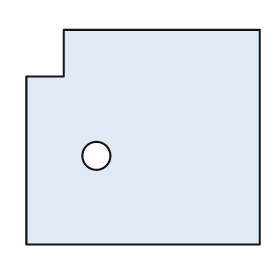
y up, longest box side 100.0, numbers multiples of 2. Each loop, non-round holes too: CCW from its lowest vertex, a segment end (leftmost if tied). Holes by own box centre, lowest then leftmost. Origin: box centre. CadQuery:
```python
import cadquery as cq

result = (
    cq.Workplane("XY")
    .moveTo(-50.0, -46.0)
    .lineTo(50.0, -46.0)
    .lineTo(50.0, 46.0)
    .lineTo(-34.0, 46.0)
    .lineTo(-34.0, 26.0)
    .lineTo(-50.0, 26.0)
    .close()
    .moveTo(-20.0, -8.0)
    .circle(6.0)
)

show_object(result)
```